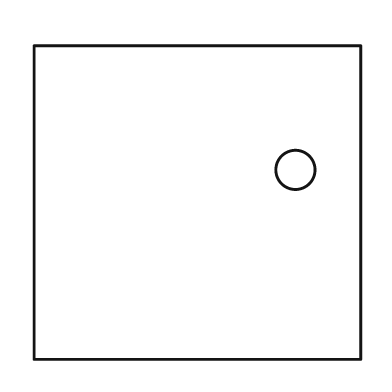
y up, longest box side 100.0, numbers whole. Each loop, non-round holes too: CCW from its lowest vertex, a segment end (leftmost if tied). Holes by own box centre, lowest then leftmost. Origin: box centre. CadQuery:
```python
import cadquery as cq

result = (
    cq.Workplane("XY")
    .moveTo(-50.0, -48.0)
    .lineTo(50.0, -48.0)
    .lineTo(50.0, 48.0)
    .lineTo(-50.0, 48.0)
    .close()
    .moveTo(30.0, 10.0)
    .circle(6.0)
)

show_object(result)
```